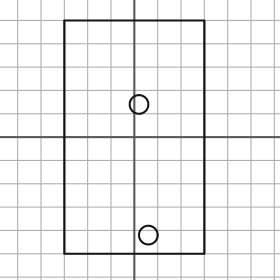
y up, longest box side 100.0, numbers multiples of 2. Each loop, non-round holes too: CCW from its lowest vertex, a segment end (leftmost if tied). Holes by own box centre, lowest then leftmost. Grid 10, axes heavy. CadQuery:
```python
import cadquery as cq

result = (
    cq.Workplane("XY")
    .moveTo(-30.0, -50.0)
    .lineTo(30.0, -50.0)
    .lineTo(30.0, 50.0)
    .lineTo(-30.0, 50.0)
    .close()
    .moveTo(6.0, -42.0)
    .circle(4.0)
    .moveTo(2.0, 14.0)
    .circle(4.0)
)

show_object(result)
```